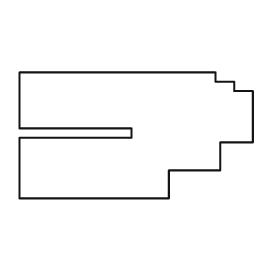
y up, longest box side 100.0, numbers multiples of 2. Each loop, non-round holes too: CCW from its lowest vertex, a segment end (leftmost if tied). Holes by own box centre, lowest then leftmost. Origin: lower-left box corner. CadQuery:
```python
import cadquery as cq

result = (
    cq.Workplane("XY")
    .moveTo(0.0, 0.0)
    .lineTo(64.0, 0.0)
    .lineTo(64.0, 12.0)
    .lineTo(86.0, 12.0)
    .lineTo(86.0, 24.0)
    .lineTo(100.0, 24.0)
    .lineTo(100.0, 46.0)
    .lineTo(92.0, 46.0)
    .lineTo(92.0, 50.0)
    .lineTo(84.0, 50.0)
    .lineTo(84.0, 54.0)
    .lineTo(0.0, 54.0)
    .lineTo(0.0, 30.0)
    .lineTo(48.0, 30.0)
    .lineTo(48.0, 26.0)
    .lineTo(0.0, 26.0)
    .close()
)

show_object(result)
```